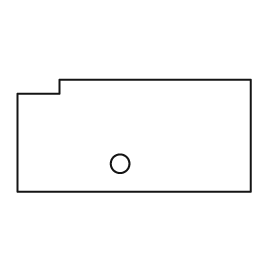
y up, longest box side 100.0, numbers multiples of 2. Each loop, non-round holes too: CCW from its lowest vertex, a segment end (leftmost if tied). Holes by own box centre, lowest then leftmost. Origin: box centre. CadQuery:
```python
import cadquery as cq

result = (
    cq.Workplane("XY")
    .moveTo(-50.0, -24.0)
    .lineTo(50.0, -24.0)
    .lineTo(50.0, 24.0)
    .lineTo(-32.0, 24.0)
    .lineTo(-32.0, 18.0)
    .lineTo(-50.0, 18.0)
    .close()
    .moveTo(-6.0, -12.0)
    .circle(4.0)
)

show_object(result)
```